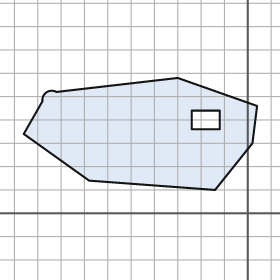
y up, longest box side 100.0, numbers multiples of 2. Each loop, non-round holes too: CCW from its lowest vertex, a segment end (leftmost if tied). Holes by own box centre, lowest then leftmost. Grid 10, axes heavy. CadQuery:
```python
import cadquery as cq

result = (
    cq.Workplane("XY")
    .moveTo(-14.0, 10.0)
    .lineTo(2.0, 30.0)
    .lineTo(4.0, 46.0)
    .lineTo(-30.0, 58.0)
    .lineTo(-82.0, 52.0)
    .threePointArc((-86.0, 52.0), (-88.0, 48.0))
    .lineTo(-96.0, 34.0)
    .lineTo(-68.0, 14.0)
    .close()
    .moveTo(-24.0, 36.0)
    .lineTo(-12.0, 36.0)
    .lineTo(-12.0, 44.0)
    .lineTo(-24.0, 44.0)
    .close()
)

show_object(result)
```